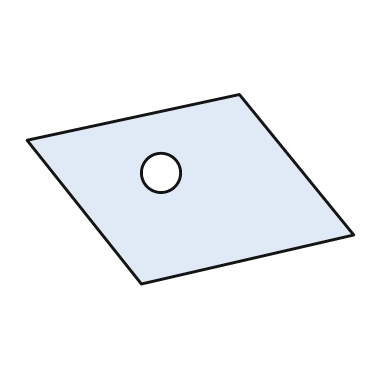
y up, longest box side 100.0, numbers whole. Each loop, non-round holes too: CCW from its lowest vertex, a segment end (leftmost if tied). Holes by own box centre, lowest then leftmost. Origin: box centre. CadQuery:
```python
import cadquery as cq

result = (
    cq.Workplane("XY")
    .moveTo(-15.0, -29.0)
    .lineTo(50.0, -14.0)
    .lineTo(15.0, 29.0)
    .lineTo(-50.0, 15.0)
    .close()
    .moveTo(-9.0, 5.0)
    .circle(6.0)
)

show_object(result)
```